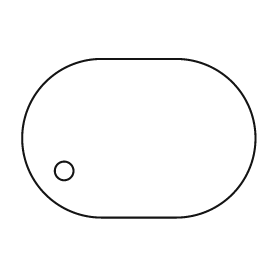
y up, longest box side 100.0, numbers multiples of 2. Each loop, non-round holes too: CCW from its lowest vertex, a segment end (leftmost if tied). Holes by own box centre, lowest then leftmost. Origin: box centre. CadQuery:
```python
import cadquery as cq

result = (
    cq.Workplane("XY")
    .moveTo(-16.0, -34.0)
    .lineTo(16.0, -34.0)
    .threePointArc((50.0, 0.0), (16.0, 34.0))
    .lineTo(-16.0, 34.0)
    .threePointArc((-50.0, 0.0), (-16.0, -34.0))
    .close()
    .moveTo(-32.0, -14.0)
    .circle(4.0)
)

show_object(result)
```